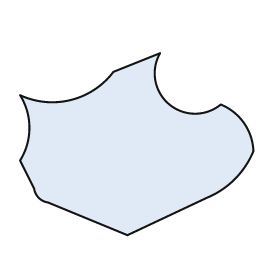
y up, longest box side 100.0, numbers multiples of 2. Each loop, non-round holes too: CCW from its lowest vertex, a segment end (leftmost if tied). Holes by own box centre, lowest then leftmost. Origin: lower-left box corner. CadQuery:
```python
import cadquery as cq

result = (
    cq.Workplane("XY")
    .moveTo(46.0, 0.0)
    .lineTo(80.0, 16.0)
    .threePointArc((92.0, 24.0), (100.0, 36.0))
    .threePointArc((96.0, 48.0), (86.0, 56.0))
    .threePointArc((64.0, 56.0), (60.0, 78.0))
    .lineTo(40.0, 70.0)
    .threePointArc((22.0, 58.0), (0.0, 60.0))
    .threePointArc((4.0, 46.0), (0.0, 32.0))
    .lineTo(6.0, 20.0)
    .threePointArc((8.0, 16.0), (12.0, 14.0))
    .close()
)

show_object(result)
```